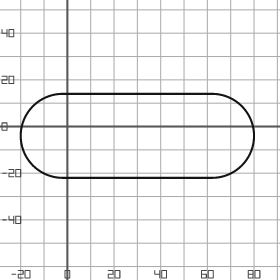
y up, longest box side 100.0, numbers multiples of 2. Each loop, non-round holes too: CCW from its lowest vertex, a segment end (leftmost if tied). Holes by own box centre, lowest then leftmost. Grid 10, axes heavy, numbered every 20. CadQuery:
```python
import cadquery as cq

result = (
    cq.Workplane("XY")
    .moveTo(-2.0, -22.0)
    .lineTo(62.0, -22.0)
    .threePointArc((80.0, -4.0), (62.0, 14.0))
    .lineTo(-2.0, 14.0)
    .threePointArc((-20.0, -4.0), (-2.0, -22.0))
    .close()
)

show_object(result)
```